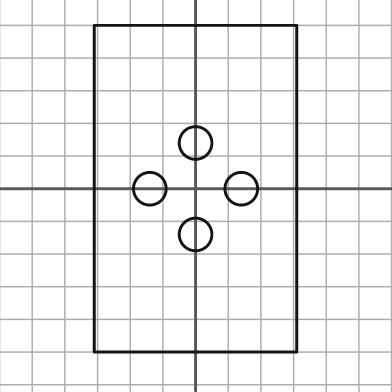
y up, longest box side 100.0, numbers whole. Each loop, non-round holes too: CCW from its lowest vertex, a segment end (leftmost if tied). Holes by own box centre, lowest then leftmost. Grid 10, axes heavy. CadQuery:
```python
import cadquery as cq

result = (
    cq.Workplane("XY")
    .moveTo(-31.0, -50.0)
    .lineTo(31.0, -50.0)
    .lineTo(31.0, 50.0)
    .lineTo(-31.0, 50.0)
    .close()
    .moveTo(0.0, -14.0)
    .circle(5.0)
    .moveTo(-14.0, 0.0)
    .circle(5.0)
    .moveTo(14.0, 0.0)
    .circle(5.0)
    .moveTo(0.0, 14.0)
    .circle(5.0)
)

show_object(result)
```